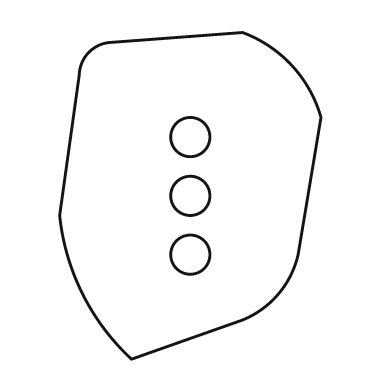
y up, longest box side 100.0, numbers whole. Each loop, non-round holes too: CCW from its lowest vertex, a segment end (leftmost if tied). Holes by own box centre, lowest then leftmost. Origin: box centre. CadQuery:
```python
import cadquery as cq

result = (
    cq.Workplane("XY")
    .moveTo(-18.0, -50.0)
    .lineTo(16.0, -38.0)
    .threePointArc((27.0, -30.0), (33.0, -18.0))
    .lineTo(40.0, 24.0)
    .threePointArc((31.0, 40.0), (16.0, 50.0))
    .lineTo(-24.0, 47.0)
    .threePointArc((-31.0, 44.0), (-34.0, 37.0))
    .lineTo(-40.0, -6.0)
    .threePointArc((-33.0, -30.0), (-18.0, -50.0))
    .close()
    .moveTo(0.0, -18.0)
    .circle(6.0)
    .moveTo(0.0, 0.0)
    .circle(6.0)
    .moveTo(0.0, 18.0)
    .circle(6.0)
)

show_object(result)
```